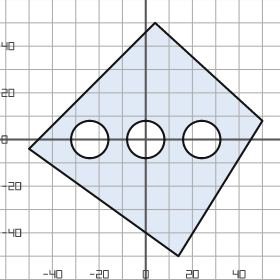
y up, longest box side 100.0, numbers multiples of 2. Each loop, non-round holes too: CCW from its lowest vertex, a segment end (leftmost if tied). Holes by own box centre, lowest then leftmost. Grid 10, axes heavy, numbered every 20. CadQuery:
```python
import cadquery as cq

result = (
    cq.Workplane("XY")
    .moveTo(14.0, -50.0)
    .lineTo(50.0, 8.0)
    .lineTo(4.0, 50.0)
    .lineTo(-50.0, -4.0)
    .close()
    .moveTo(-24.0, 0.0)
    .circle(8.0)
    .moveTo(0.0, 0.0)
    .circle(8.0)
    .moveTo(24.0, 0.0)
    .circle(8.0)
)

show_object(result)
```